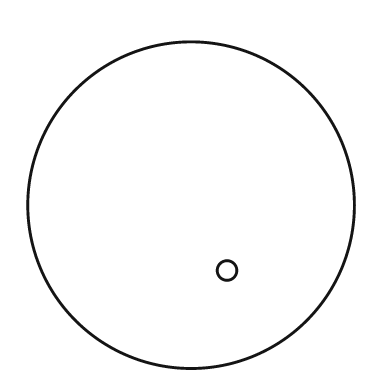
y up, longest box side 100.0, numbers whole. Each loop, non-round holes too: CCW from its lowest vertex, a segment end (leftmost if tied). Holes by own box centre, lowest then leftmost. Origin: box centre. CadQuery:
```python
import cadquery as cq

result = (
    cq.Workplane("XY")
    .moveTo(0.0, 0.0)
    .circle(50.0)
    .moveTo(11.0, -20.0)
    .circle(3.0)
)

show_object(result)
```